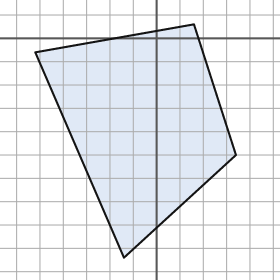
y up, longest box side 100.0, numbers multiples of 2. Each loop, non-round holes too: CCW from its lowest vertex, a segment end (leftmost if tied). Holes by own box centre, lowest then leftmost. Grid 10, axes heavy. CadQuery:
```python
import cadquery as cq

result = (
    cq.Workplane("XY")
    .moveTo(-14.0, -94.0)
    .lineTo(34.0, -50.0)
    .lineTo(16.0, 6.0)
    .lineTo(-52.0, -6.0)
    .close()
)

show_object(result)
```